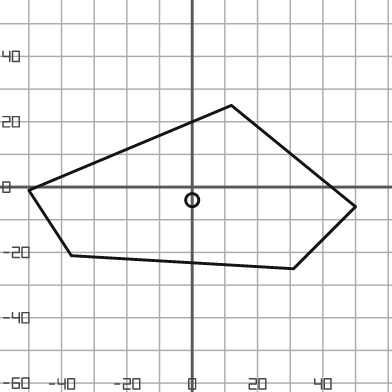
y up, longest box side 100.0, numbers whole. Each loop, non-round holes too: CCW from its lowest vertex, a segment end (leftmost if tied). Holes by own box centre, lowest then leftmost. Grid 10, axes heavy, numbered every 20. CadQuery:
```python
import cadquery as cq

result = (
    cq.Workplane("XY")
    .moveTo(31.0, -25.0)
    .lineTo(50.0, -6.0)
    .lineTo(12.0, 25.0)
    .lineTo(-50.0, -1.0)
    .lineTo(-37.0, -21.0)
    .close()
    .moveTo(0.0, -4.0)
    .circle(2.0)
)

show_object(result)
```